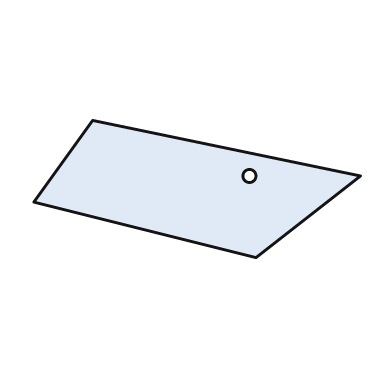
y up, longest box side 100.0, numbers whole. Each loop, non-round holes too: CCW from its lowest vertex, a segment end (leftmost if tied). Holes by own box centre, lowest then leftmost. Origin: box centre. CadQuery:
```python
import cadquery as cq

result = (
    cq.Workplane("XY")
    .moveTo(18.0, -21.0)
    .lineTo(50.0, 4.0)
    .lineTo(-32.0, 21.0)
    .lineTo(-50.0, -4.0)
    .close()
    .moveTo(16.0, 4.0)
    .circle(2.0)
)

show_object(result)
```